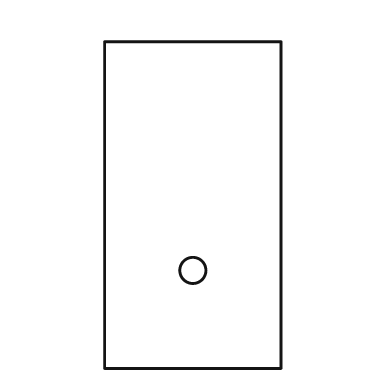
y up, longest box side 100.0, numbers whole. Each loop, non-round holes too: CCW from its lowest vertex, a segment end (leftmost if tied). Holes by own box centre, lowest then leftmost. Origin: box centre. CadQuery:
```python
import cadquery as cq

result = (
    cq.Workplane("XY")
    .moveTo(-27.0, -50.0)
    .lineTo(27.0, -50.0)
    .lineTo(27.0, 50.0)
    .lineTo(-27.0, 50.0)
    .close()
    .moveTo(0.0, -20.0)
    .circle(4.0)
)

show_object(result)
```